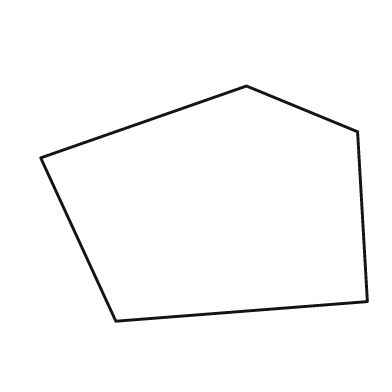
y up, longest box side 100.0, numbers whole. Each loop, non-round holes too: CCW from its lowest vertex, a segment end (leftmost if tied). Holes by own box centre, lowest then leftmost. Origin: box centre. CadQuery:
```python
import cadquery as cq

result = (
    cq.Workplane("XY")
    .moveTo(-27.0, -36.0)
    .lineTo(50.0, -30.0)
    .lineTo(47.0, 22.0)
    .lineTo(13.0, 36.0)
    .lineTo(-50.0, 14.0)
    .close()
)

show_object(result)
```